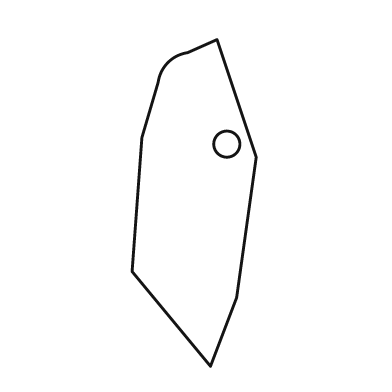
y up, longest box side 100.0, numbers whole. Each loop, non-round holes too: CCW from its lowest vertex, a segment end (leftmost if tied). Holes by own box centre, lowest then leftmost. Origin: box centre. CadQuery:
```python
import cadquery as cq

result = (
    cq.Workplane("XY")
    .moveTo(5.0, -50.0)
    .lineTo(13.0, -29.0)
    .lineTo(19.0, 14.0)
    .lineTo(7.0, 50.0)
    .lineTo(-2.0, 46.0)
    .threePointArc((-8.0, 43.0), (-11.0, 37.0))
    .lineTo(-16.0, 20.0)
    .lineTo(-19.0, -21.0)
    .close()
    .moveTo(10.0, 18.0)
    .circle(4.0)
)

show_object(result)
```